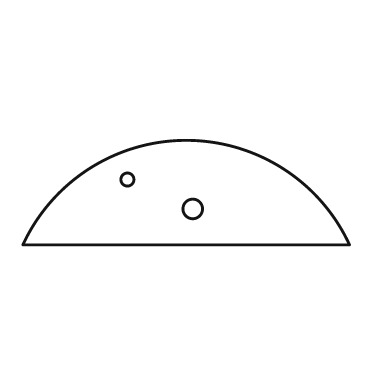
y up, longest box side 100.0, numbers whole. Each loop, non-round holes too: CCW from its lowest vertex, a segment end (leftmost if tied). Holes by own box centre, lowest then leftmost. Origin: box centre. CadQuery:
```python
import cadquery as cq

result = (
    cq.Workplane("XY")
    .moveTo(-50.0, -16.0)
    .lineTo(50.0, -16.0)
    .threePointArc((0.0, 16.0), (-50.0, -16.0))
    .close()
    .moveTo(2.0, -5.0)
    .circle(3.0)
    .moveTo(-18.0, 4.0)
    .circle(2.0)
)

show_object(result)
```